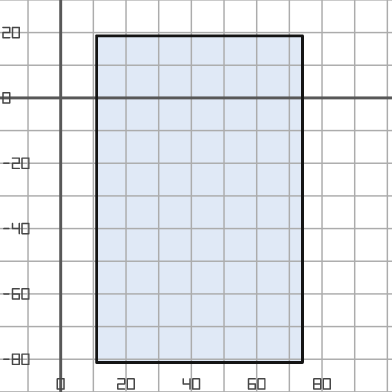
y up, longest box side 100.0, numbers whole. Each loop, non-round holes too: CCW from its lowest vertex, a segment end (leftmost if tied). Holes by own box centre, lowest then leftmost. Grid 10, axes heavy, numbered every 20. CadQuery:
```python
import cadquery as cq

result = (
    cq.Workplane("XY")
    .moveTo(11.0, -81.0)
    .lineTo(74.0, -81.0)
    .lineTo(74.0, 19.0)
    .lineTo(11.0, 19.0)
    .close()
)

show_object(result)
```